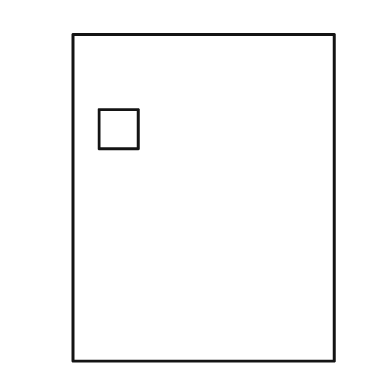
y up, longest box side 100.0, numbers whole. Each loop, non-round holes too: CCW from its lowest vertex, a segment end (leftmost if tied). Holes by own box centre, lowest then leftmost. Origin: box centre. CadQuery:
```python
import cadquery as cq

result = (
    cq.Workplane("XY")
    .moveTo(-40.0, -50.0)
    .lineTo(40.0, -50.0)
    .lineTo(40.0, 50.0)
    .lineTo(-40.0, 50.0)
    .close()
    .moveTo(-32.0, 15.0)
    .lineTo(-20.0, 15.0)
    .lineTo(-20.0, 27.0)
    .lineTo(-32.0, 27.0)
    .close()
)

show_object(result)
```